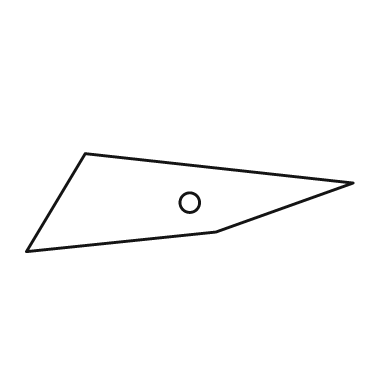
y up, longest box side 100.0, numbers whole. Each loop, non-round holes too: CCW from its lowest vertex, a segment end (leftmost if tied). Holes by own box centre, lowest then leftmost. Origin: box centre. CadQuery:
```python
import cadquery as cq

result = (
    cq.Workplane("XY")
    .moveTo(-50.0, -15.0)
    .lineTo(8.0, -9.0)
    .lineTo(50.0, 6.0)
    .lineTo(-32.0, 15.0)
    .close()
    .moveTo(0.0, 0.0)
    .circle(3.0)
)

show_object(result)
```